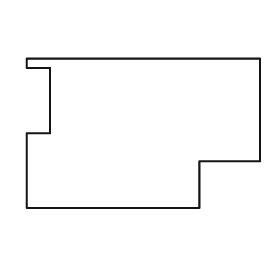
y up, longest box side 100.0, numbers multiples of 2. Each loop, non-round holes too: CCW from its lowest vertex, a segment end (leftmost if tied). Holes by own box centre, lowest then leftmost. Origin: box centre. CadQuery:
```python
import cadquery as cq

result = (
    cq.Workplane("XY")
    .moveTo(-50.0, -32.0)
    .lineTo(24.0, -32.0)
    .lineTo(24.0, -12.0)
    .lineTo(50.0, -12.0)
    .lineTo(50.0, 32.0)
    .lineTo(-50.0, 32.0)
    .lineTo(-50.0, 28.0)
    .lineTo(-40.0, 28.0)
    .lineTo(-40.0, 0.0)
    .lineTo(-50.0, 0.0)
    .close()
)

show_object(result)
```